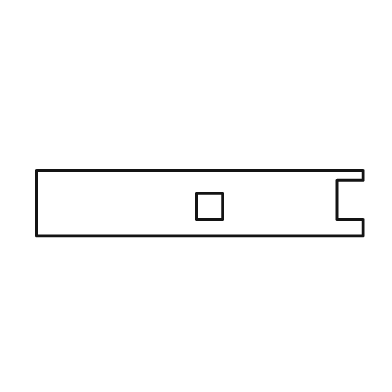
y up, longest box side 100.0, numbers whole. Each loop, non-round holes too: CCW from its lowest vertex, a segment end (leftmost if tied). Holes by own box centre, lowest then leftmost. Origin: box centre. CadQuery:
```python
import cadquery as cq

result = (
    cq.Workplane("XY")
    .moveTo(-50.0, -10.0)
    .lineTo(50.0, -10.0)
    .lineTo(50.0, -5.0)
    .lineTo(42.0, -5.0)
    .lineTo(42.0, 7.0)
    .lineTo(50.0, 7.0)
    .lineTo(50.0, 10.0)
    .lineTo(-50.0, 10.0)
    .close()
    .moveTo(-1.0, -5.0)
    .lineTo(7.0, -5.0)
    .lineTo(7.0, 3.0)
    .lineTo(-1.0, 3.0)
    .close()
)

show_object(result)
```